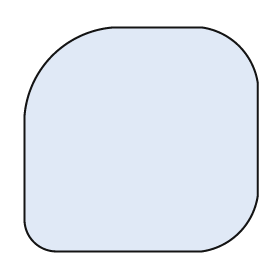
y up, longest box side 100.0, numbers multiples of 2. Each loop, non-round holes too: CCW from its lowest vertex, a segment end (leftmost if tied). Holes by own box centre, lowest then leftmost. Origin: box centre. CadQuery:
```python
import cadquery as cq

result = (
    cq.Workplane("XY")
    .moveTo(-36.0, -48.0)
    .lineTo(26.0, -48.0)
    .threePointArc((42.0, -40.0), (50.0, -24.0))
    .lineTo(50.0, 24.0)
    .threePointArc((42.0, 40.0), (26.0, 48.0))
    .lineTo(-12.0, 48.0)
    .threePointArc((-38.0, 36.0), (-50.0, 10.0))
    .lineTo(-50.0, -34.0)
    .threePointArc((-46.0, -44.0), (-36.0, -48.0))
    .close()
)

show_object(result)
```